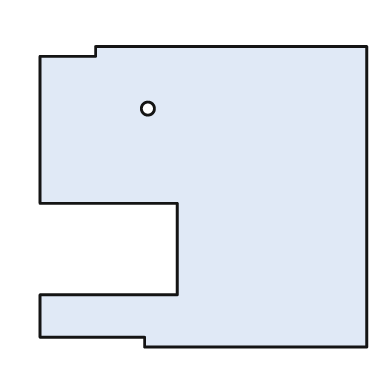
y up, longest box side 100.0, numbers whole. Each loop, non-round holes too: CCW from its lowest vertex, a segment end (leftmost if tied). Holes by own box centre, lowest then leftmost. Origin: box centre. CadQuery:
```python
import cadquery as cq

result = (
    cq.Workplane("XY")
    .moveTo(-18.0, -46.0)
    .lineTo(50.0, -46.0)
    .lineTo(50.0, 46.0)
    .lineTo(-33.0, 46.0)
    .lineTo(-33.0, 43.0)
    .lineTo(-50.0, 43.0)
    .lineTo(-50.0, -2.0)
    .lineTo(-8.0, -2.0)
    .lineTo(-8.0, -30.0)
    .lineTo(-50.0, -30.0)
    .lineTo(-50.0, -43.0)
    .lineTo(-18.0, -43.0)
    .close()
    .moveTo(-17.0, 27.0)
    .circle(2.0)
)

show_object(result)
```